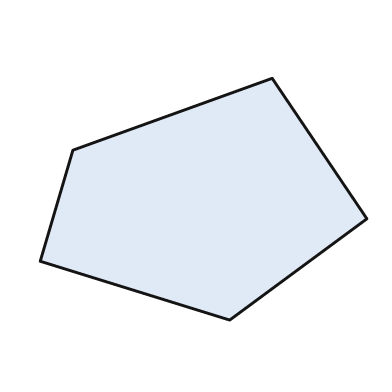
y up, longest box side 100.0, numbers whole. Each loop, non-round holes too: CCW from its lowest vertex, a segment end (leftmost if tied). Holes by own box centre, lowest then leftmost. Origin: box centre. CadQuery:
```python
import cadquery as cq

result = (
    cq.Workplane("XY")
    .moveTo(8.0, -37.0)
    .lineTo(50.0, -6.0)
    .lineTo(21.0, 37.0)
    .lineTo(-40.0, 15.0)
    .lineTo(-50.0, -19.0)
    .close()
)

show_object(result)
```